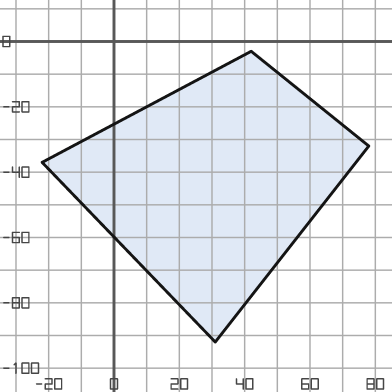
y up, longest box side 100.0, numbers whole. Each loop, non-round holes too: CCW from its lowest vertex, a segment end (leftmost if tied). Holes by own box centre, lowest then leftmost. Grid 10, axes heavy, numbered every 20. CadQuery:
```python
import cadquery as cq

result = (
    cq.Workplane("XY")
    .moveTo(31.0, -92.0)
    .lineTo(78.0, -32.0)
    .lineTo(42.0, -3.0)
    .lineTo(-22.0, -37.0)
    .close()
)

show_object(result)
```